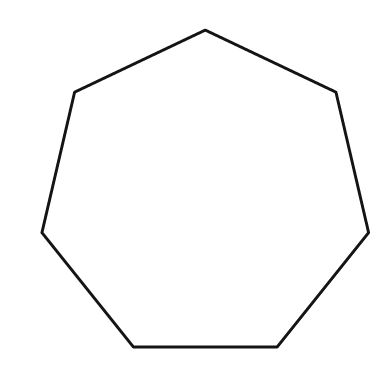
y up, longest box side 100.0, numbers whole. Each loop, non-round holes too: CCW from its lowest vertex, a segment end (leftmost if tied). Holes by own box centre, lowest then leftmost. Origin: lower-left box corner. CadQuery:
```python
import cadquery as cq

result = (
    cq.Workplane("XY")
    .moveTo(28.0, 0.0)
    .lineTo(72.0, 0.0)
    .lineTo(100.0, 35.0)
    .lineTo(90.0, 78.0)
    .lineTo(50.0, 97.0)
    .lineTo(10.0, 78.0)
    .lineTo(0.0, 35.0)
    .close()
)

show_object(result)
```